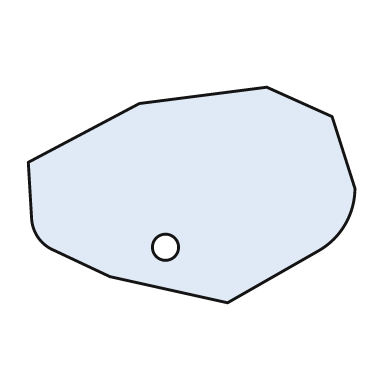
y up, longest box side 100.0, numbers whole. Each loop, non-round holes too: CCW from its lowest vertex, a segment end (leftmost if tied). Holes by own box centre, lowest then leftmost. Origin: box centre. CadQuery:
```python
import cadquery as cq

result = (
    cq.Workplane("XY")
    .moveTo(11.0, -33.0)
    .lineTo(39.0, -17.0)
    .threePointArc((47.0, -9.0), (50.0, 2.0))
    .lineTo(43.0, 24.0)
    .lineTo(23.0, 33.0)
    .lineTo(-16.0, 28.0)
    .lineTo(-50.0, 10.0)
    .lineTo(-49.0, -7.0)
    .threePointArc((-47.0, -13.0), (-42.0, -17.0))
    .lineTo(-25.0, -25.0)
    .close()
    .moveTo(-8.0, -16.0)
    .circle(4.0)
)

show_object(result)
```